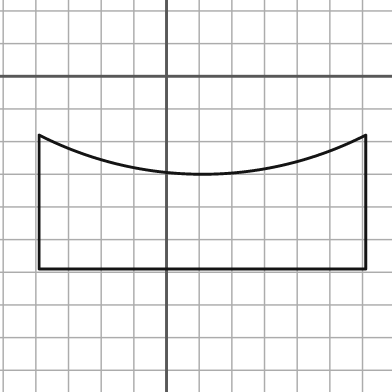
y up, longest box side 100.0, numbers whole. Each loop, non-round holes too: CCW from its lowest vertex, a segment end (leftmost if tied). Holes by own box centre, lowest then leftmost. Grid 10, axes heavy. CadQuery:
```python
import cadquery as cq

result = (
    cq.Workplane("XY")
    .moveTo(-39.0, -59.0)
    .lineTo(61.0, -59.0)
    .lineTo(61.0, -18.0)
    .threePointArc((11.0, -30.0), (-39.0, -18.0))
    .close()
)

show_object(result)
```